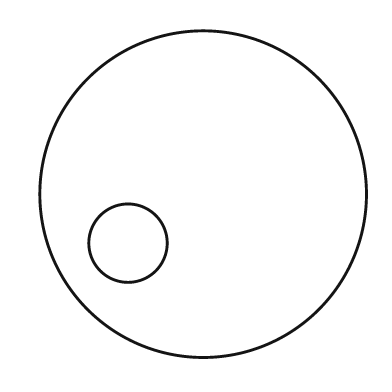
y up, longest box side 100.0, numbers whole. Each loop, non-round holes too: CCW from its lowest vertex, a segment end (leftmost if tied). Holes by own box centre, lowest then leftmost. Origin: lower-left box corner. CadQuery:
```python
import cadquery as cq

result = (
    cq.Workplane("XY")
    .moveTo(50.0, 50.0)
    .circle(50.0)
    .moveTo(27.0, 35.0)
    .circle(12.0)
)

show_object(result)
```